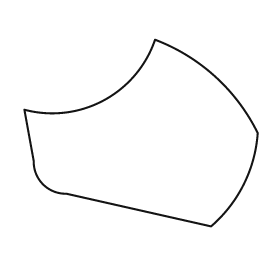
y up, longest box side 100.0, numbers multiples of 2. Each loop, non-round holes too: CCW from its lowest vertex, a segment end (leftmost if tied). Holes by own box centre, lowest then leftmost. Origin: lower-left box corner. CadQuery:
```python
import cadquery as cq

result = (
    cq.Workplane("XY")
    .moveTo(80.0, 0.0)
    .threePointArc((94.0, 18.0), (100.0, 40.0))
    .threePointArc((82.0, 64.0), (56.0, 80.0))
    .threePointArc((34.0, 54.0), (0.0, 50.0))
    .lineTo(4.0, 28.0)
    .threePointArc((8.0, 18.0), (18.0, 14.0))
    .close()
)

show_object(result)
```